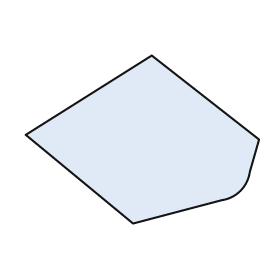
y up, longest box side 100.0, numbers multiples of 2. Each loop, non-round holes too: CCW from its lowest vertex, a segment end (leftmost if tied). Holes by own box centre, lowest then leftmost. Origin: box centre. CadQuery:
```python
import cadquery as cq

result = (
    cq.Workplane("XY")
    .moveTo(-4.0, -36.0)
    .lineTo(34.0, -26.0)
    .threePointArc((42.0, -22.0), (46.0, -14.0))
    .lineTo(50.0, 0.0)
    .lineTo(4.0, 36.0)
    .lineTo(-50.0, 2.0)
    .close()
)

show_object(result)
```